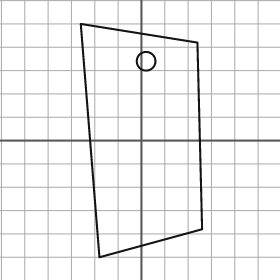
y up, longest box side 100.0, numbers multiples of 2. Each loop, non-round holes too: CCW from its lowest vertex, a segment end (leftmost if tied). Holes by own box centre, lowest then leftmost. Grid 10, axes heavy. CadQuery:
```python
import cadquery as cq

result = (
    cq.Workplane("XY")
    .moveTo(-18.0, -50.0)
    .lineTo(26.0, -38.0)
    .lineTo(24.0, 42.0)
    .lineTo(-26.0, 50.0)
    .close()
    .moveTo(2.0, 34.0)
    .circle(4.0)
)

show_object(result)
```